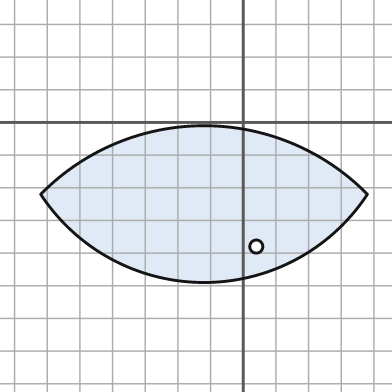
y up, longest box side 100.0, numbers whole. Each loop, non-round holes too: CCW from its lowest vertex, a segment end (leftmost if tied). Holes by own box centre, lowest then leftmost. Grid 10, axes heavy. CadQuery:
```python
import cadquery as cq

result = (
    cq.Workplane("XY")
    .moveTo(-62.0, -22.0)
    .threePointArc((-12.0, -49.0), (38.0, -22.0))
    .threePointArc((-12.0, -1.0), (-62.0, -22.0))
    .close()
    .moveTo(4.0, -38.0)
    .circle(2.0)
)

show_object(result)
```